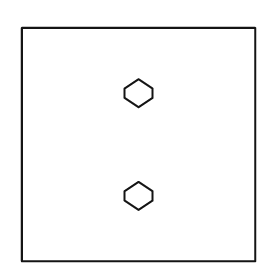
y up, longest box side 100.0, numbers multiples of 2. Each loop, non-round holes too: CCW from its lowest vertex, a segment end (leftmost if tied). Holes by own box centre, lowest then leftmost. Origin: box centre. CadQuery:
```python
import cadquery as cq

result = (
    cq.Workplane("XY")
    .moveTo(-50.0, -50.0)
    .lineTo(50.0, -50.0)
    .lineTo(50.0, 50.0)
    .lineTo(-50.0, 50.0)
    .close()
    .moveTo(0.0, -28.0)
    .lineTo(6.0, -24.0)
    .lineTo(6.0, -20.0)
    .lineTo(0.0, -16.0)
    .lineTo(-6.0, -20.0)
    .lineTo(-6.0, -24.0)
    .close()
    .moveTo(0.0, 16.0)
    .lineTo(6.0, 20.0)
    .lineTo(6.0, 24.0)
    .lineTo(0.0, 28.0)
    .lineTo(-6.0, 24.0)
    .lineTo(-6.0, 20.0)
    .close()
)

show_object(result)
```